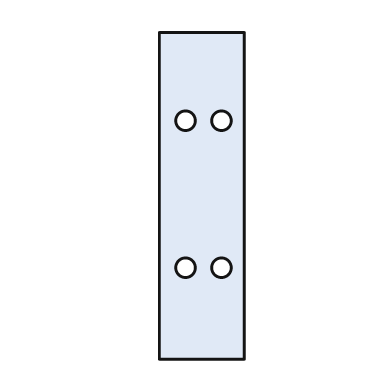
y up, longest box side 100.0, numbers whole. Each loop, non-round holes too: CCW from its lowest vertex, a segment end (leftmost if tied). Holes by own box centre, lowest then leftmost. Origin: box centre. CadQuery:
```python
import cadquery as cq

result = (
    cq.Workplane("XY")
    .moveTo(-13.0, -50.0)
    .lineTo(13.0, -50.0)
    .lineTo(13.0, 50.0)
    .lineTo(-13.0, 50.0)
    .close()
    .moveTo(-5.0, -22.0)
    .circle(3.0)
    .moveTo(6.0, -22.0)
    .circle(3.0)
    .moveTo(-5.0, 23.0)
    .circle(3.0)
    .moveTo(6.0, 23.0)
    .circle(3.0)
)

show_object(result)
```